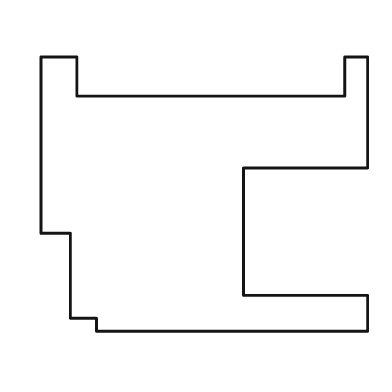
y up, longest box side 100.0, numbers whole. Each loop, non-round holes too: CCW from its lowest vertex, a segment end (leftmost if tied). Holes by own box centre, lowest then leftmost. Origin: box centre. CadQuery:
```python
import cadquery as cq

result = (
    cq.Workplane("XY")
    .moveTo(-33.0, -42.0)
    .lineTo(50.0, -42.0)
    .lineTo(50.0, -31.0)
    .lineTo(12.0, -31.0)
    .lineTo(12.0, 8.0)
    .lineTo(50.0, 8.0)
    .lineTo(50.0, 42.0)
    .lineTo(43.0, 42.0)
    .lineTo(43.0, 30.0)
    .lineTo(-39.0, 30.0)
    .lineTo(-39.0, 42.0)
    .lineTo(-50.0, 42.0)
    .lineTo(-50.0, -12.0)
    .lineTo(-41.0, -12.0)
    .lineTo(-41.0, -38.0)
    .lineTo(-33.0, -38.0)
    .close()
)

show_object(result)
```